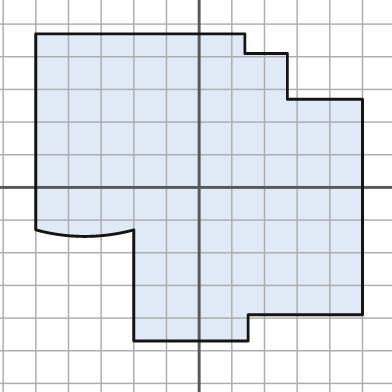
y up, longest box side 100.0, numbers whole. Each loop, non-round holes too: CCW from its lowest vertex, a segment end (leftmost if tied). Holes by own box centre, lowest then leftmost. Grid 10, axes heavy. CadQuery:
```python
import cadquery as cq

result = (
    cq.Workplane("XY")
    .moveTo(-20.0, -47.0)
    .lineTo(15.0, -47.0)
    .lineTo(15.0, -39.0)
    .lineTo(50.0, -39.0)
    .lineTo(50.0, 27.0)
    .lineTo(27.0, 27.0)
    .lineTo(27.0, 41.0)
    .lineTo(14.0, 41.0)
    .lineTo(14.0, 47.0)
    .lineTo(-50.0, 47.0)
    .lineTo(-50.0, -13.0)
    .threePointArc((-35.0, -15.0), (-20.0, -13.0))
    .close()
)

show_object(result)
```